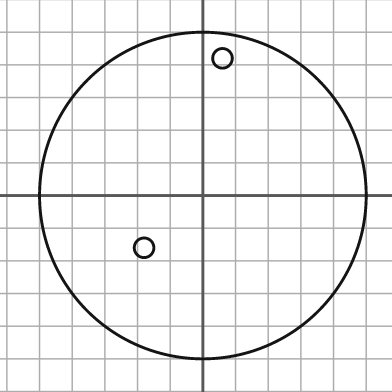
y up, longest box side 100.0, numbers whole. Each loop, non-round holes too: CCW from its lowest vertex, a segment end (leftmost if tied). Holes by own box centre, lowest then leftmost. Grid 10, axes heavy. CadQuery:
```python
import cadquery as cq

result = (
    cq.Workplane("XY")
    .moveTo(0.0, 0.0)
    .circle(50.0)
    .moveTo(-18.0, -16.0)
    .circle(3.0)
    .moveTo(6.0, 42.0)
    .circle(3.0)
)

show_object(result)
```